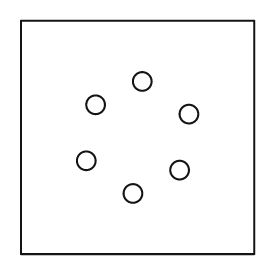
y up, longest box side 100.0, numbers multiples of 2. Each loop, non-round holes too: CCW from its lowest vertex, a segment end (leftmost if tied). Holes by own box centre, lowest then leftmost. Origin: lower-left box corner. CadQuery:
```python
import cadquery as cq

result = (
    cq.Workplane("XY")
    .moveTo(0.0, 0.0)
    .lineTo(100.0, 0.0)
    .lineTo(100.0, 100.0)
    .lineTo(0.0, 100.0)
    .close()
    .moveTo(48.0, 26.0)
    .circle(4.0)
    .moveTo(68.0, 36.0)
    .circle(4.0)
    .moveTo(28.0, 40.0)
    .circle(4.0)
    .moveTo(72.0, 60.0)
    .circle(4.0)
    .moveTo(32.0, 64.0)
    .circle(4.0)
    .moveTo(52.0, 74.0)
    .circle(4.0)
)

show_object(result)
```